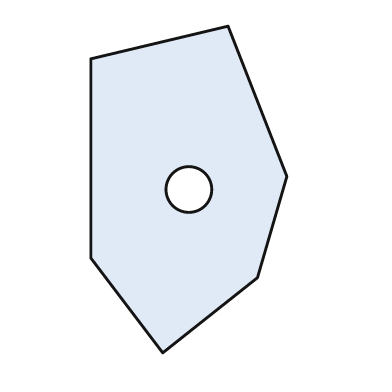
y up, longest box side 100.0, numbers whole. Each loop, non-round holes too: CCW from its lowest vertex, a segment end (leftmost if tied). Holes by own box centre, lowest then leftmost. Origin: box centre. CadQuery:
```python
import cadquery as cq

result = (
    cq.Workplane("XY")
    .moveTo(-8.0, -50.0)
    .lineTo(21.0, -27.0)
    .lineTo(30.0, 4.0)
    .lineTo(12.0, 50.0)
    .lineTo(-30.0, 40.0)
    .lineTo(-30.0, -21.0)
    .close()
    .moveTo(0.0, 0.0)
    .circle(7.0)
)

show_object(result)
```